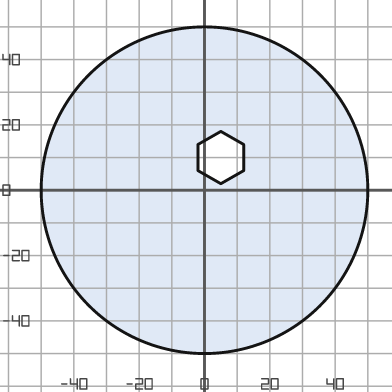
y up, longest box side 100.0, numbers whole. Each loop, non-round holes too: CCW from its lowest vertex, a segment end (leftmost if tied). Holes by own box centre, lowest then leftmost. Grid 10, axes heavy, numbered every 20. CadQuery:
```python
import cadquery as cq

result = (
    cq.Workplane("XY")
    .moveTo(0.0, 0.0)
    .circle(50.0)
    .moveTo(5.0, 2.0)
    .lineTo(12.0, 6.0)
    .lineTo(12.0, 14.0)
    .lineTo(5.0, 18.0)
    .lineTo(-2.0, 14.0)
    .lineTo(-2.0, 6.0)
    .close()
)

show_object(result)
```